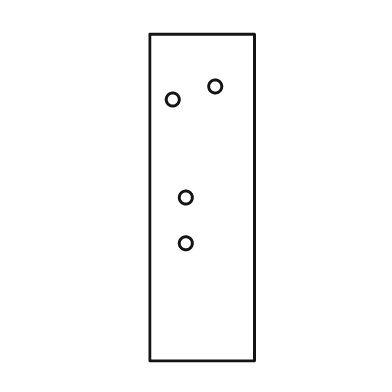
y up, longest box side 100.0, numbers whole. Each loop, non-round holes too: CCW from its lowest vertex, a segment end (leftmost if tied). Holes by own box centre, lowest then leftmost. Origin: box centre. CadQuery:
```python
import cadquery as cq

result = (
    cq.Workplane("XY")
    .moveTo(-16.0, -50.0)
    .lineTo(16.0, -50.0)
    .lineTo(16.0, 50.0)
    .lineTo(-16.0, 50.0)
    .close()
    .moveTo(-5.0, -14.0)
    .circle(2.0)
    .moveTo(-5.0, 0.0)
    .circle(2.0)
    .moveTo(-9.0, 30.0)
    .circle(2.0)
    .moveTo(4.0, 34.0)
    .circle(2.0)
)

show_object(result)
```